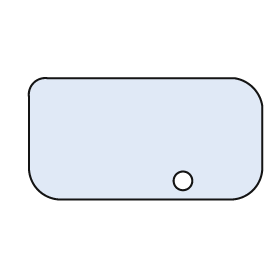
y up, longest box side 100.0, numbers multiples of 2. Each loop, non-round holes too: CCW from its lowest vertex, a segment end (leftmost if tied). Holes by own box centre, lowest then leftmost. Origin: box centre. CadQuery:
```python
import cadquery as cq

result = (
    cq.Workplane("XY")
    .moveTo(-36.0, -26.0)
    .lineTo(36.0, -26.0)
    .threePointArc((46.0, -22.0), (50.0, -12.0))
    .lineTo(50.0, 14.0)
    .threePointArc((46.0, 22.0), (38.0, 26.0))
    .lineTo(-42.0, 26.0)
    .threePointArc((-48.0, 24.0), (-50.0, 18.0))
    .lineTo(-50.0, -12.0)
    .threePointArc((-46.0, -22.0), (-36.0, -26.0))
    .close()
    .moveTo(16.0, -18.0)
    .circle(4.0)
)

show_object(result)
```